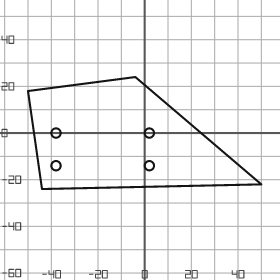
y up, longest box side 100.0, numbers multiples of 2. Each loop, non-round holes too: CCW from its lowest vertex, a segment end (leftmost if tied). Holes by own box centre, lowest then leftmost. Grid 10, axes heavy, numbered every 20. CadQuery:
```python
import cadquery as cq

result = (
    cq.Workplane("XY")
    .moveTo(-44.0, -24.0)
    .lineTo(50.0, -22.0)
    .lineTo(-4.0, 24.0)
    .lineTo(-50.0, 18.0)
    .close()
    .moveTo(-38.0, -14.0)
    .circle(2.0)
    .moveTo(2.0, -14.0)
    .circle(2.0)
    .moveTo(-38.0, 0.0)
    .circle(2.0)
    .moveTo(2.0, 0.0)
    .circle(2.0)
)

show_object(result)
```